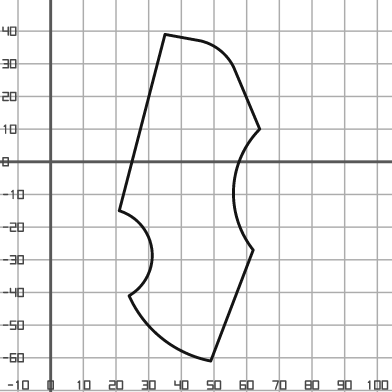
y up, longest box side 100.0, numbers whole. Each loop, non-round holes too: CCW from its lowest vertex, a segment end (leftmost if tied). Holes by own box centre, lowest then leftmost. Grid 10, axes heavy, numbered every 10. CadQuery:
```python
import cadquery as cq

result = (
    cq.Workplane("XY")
    .moveTo(49.0, -61.0)
    .lineTo(62.0, -27.0)
    .threePointArc((56.0, -8.0), (64.0, 10.0))
    .lineTo(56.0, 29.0)
    .threePointArc((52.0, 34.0), (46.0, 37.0))
    .lineTo(35.0, 39.0)
    .lineTo(21.0, -15.0)
    .threePointArc((31.0, -27.0), (24.0, -41.0))
    .threePointArc((34.0, -54.0), (49.0, -61.0))
    .close()
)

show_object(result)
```